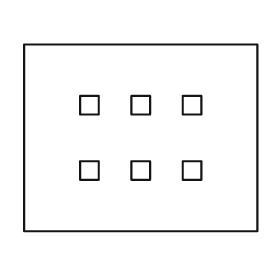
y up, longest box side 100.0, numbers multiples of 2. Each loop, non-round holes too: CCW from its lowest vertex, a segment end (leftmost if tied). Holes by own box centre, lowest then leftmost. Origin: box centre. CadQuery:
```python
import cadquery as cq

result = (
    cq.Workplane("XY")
    .moveTo(-50.0, -40.0)
    .lineTo(50.0, -40.0)
    .lineTo(50.0, 40.0)
    .lineTo(-50.0, 40.0)
    .close()
    .moveTo(-26.0, -18.0)
    .lineTo(-18.0, -18.0)
    .lineTo(-18.0, -10.0)
    .lineTo(-26.0, -10.0)
    .close()
    .moveTo(-4.0, -18.0)
    .lineTo(4.0, -18.0)
    .lineTo(4.0, -10.0)
    .lineTo(-4.0, -10.0)
    .close()
    .moveTo(18.0, -18.0)
    .lineTo(26.0, -18.0)
    .lineTo(26.0, -10.0)
    .lineTo(18.0, -10.0)
    .close()
    .moveTo(-26.0, 10.0)
    .lineTo(-18.0, 10.0)
    .lineTo(-18.0, 18.0)
    .lineTo(-26.0, 18.0)
    .close()
    .moveTo(-4.0, 10.0)
    .lineTo(4.0, 10.0)
    .lineTo(4.0, 18.0)
    .lineTo(-4.0, 18.0)
    .close()
    .moveTo(18.0, 10.0)
    .lineTo(26.0, 10.0)
    .lineTo(26.0, 18.0)
    .lineTo(18.0, 18.0)
    .close()
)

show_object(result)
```